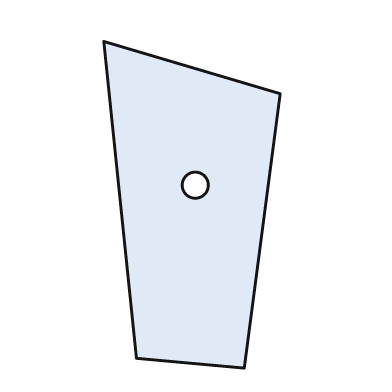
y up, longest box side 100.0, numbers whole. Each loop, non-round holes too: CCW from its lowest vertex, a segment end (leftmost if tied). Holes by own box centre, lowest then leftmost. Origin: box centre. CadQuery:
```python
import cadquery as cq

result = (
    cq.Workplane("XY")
    .moveTo(16.0, -50.0)
    .lineTo(27.0, 34.0)
    .lineTo(-27.0, 50.0)
    .lineTo(-17.0, -47.0)
    .close()
    .moveTo(1.0, 6.0)
    .circle(4.0)
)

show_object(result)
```